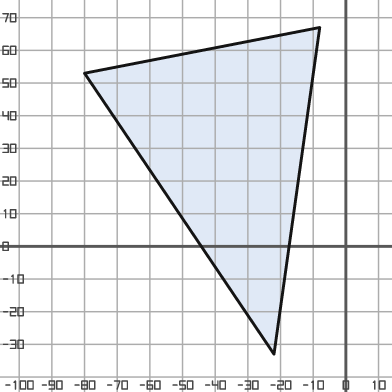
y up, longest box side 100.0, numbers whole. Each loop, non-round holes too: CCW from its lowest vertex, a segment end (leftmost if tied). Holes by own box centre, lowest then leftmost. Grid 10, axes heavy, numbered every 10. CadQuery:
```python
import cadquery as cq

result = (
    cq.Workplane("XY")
    .moveTo(-22.0, -33.0)
    .lineTo(-8.0, 67.0)
    .lineTo(-80.0, 53.0)
    .close()
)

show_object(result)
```